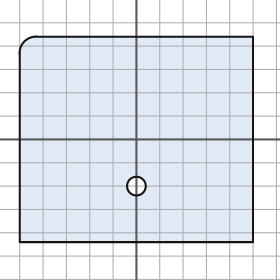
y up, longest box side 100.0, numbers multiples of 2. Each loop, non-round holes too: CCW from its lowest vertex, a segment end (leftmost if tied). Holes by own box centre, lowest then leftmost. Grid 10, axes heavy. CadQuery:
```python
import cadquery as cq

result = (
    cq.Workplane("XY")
    .moveTo(-50.0, -44.0)
    .lineTo(50.0, -44.0)
    .lineTo(50.0, 44.0)
    .lineTo(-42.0, 44.0)
    .threePointArc((-48.0, 42.0), (-50.0, 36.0))
    .close()
    .moveTo(0.0, -20.0)
    .circle(4.0)
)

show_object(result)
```